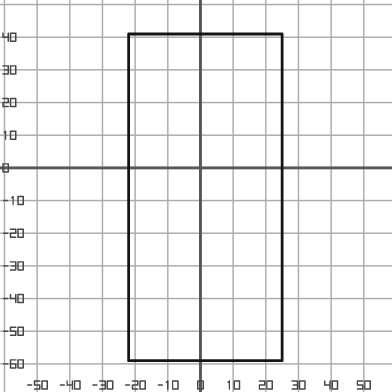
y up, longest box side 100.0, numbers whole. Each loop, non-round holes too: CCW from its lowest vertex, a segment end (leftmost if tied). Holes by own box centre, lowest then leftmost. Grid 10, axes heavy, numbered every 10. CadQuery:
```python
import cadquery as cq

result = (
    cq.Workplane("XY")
    .moveTo(-22.0, -59.0)
    .lineTo(25.0, -59.0)
    .lineTo(25.0, 41.0)
    .lineTo(-22.0, 41.0)
    .close()
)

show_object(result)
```